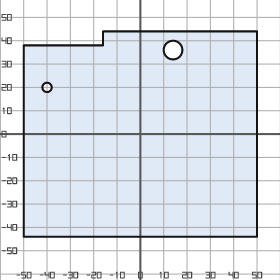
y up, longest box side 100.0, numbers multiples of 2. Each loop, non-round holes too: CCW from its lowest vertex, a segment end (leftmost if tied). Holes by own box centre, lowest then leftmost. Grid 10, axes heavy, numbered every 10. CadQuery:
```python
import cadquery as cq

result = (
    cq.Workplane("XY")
    .moveTo(-50.0, -44.0)
    .lineTo(50.0, -44.0)
    .lineTo(50.0, 44.0)
    .lineTo(-16.0, 44.0)
    .lineTo(-16.0, 38.0)
    .lineTo(-50.0, 38.0)
    .close()
    .moveTo(-40.0, 20.0)
    .circle(2.0)
    .moveTo(14.0, 36.0)
    .circle(4.0)
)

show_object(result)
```